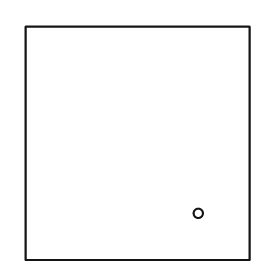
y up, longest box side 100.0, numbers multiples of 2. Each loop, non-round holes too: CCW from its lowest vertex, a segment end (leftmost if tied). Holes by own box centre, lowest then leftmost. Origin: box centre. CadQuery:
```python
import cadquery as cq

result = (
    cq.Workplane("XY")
    .moveTo(-48.0, -50.0)
    .lineTo(48.0, -50.0)
    .lineTo(48.0, 50.0)
    .lineTo(-48.0, 50.0)
    .close()
    .moveTo(26.0, -30.0)
    .circle(2.0)
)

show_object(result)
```